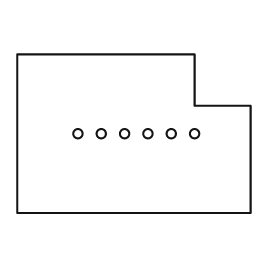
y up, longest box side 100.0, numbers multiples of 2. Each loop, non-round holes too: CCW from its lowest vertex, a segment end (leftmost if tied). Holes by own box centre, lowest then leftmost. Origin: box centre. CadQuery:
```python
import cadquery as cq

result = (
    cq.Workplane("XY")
    .moveTo(-50.0, -34.0)
    .lineTo(50.0, -34.0)
    .lineTo(50.0, 12.0)
    .lineTo(26.0, 12.0)
    .lineTo(26.0, 34.0)
    .lineTo(-50.0, 34.0)
    .close()
    .moveTo(-24.0, 0.0)
    .circle(2.0)
    .moveTo(-14.0, 0.0)
    .circle(2.0)
    .moveTo(-4.0, 0.0)
    .circle(2.0)
    .moveTo(6.0, 0.0)
    .circle(2.0)
    .moveTo(16.0, 0.0)
    .circle(2.0)
    .moveTo(26.0, 0.0)
    .circle(2.0)
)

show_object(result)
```